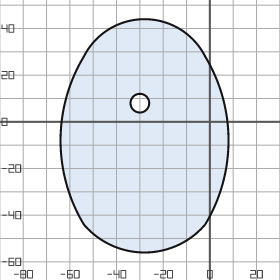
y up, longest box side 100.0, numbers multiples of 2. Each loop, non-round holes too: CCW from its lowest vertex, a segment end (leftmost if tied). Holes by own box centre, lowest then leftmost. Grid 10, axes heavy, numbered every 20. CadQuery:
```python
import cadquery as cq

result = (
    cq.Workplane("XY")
    .moveTo(-54.0, -44.0)
    .threePointArc((-28.0, -56.0), (-2.0, -44.0))
    .threePointArc((8.0, -8.0), (-2.0, 28.0))
    .threePointArc((-28.0, 44.0), (-54.0, 28.0))
    .threePointArc((-64.0, -8.0), (-54.0, -44.0))
    .close()
    .moveTo(-30.0, 8.0)
    .circle(4.0)
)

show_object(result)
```